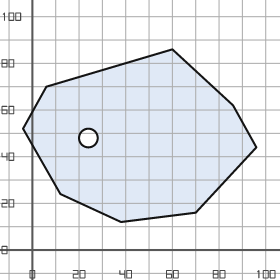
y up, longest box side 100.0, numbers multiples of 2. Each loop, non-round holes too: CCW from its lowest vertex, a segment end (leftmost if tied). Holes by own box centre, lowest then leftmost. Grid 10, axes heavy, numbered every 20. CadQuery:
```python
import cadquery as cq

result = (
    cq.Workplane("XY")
    .moveTo(38.0, 12.0)
    .lineTo(70.0, 16.0)
    .lineTo(96.0, 44.0)
    .lineTo(86.0, 62.0)
    .lineTo(60.0, 86.0)
    .lineTo(6.0, 70.0)
    .lineTo(-4.0, 52.0)
    .lineTo(12.0, 24.0)
    .close()
    .moveTo(24.0, 48.0)
    .circle(4.0)
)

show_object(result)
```